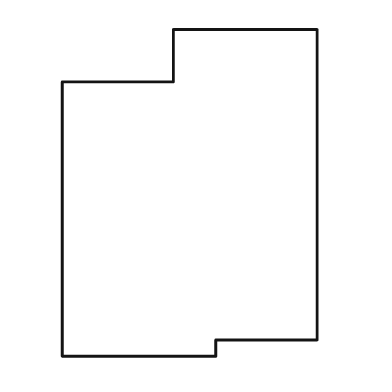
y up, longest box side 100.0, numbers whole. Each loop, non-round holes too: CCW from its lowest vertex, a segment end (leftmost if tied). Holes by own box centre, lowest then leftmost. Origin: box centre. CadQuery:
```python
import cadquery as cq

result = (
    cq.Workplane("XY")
    .moveTo(-39.0, -50.0)
    .lineTo(8.0, -50.0)
    .lineTo(8.0, -45.0)
    .lineTo(39.0, -45.0)
    .lineTo(39.0, 50.0)
    .lineTo(-5.0, 50.0)
    .lineTo(-5.0, 34.0)
    .lineTo(-39.0, 34.0)
    .close()
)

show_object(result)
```